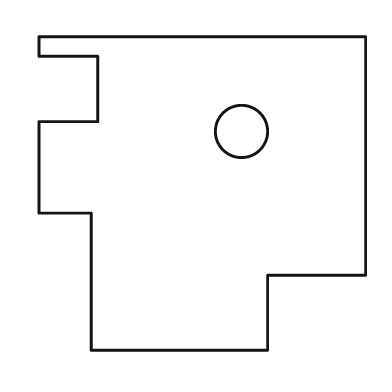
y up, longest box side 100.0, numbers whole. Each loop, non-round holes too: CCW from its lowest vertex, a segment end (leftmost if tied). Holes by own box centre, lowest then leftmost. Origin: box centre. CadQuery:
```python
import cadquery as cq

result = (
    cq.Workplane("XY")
    .moveTo(-34.0, -48.0)
    .lineTo(20.0, -48.0)
    .lineTo(20.0, -25.0)
    .lineTo(50.0, -25.0)
    .lineTo(50.0, 48.0)
    .lineTo(-50.0, 48.0)
    .lineTo(-50.0, 42.0)
    .lineTo(-32.0, 42.0)
    .lineTo(-32.0, 22.0)
    .lineTo(-50.0, 22.0)
    .lineTo(-50.0, -6.0)
    .lineTo(-34.0, -6.0)
    .close()
    .moveTo(12.0, 19.0)
    .circle(8.0)
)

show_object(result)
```